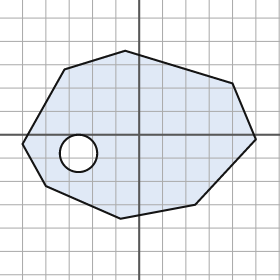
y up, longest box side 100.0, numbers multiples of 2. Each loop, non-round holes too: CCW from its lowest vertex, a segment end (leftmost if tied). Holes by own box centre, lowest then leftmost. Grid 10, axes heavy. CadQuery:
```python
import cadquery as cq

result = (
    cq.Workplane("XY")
    .moveTo(-8.0, -36.0)
    .lineTo(24.0, -30.0)
    .lineTo(50.0, -2.0)
    .lineTo(40.0, 22.0)
    .lineTo(-6.0, 36.0)
    .lineTo(-32.0, 28.0)
    .lineTo(-50.0, -4.0)
    .lineTo(-40.0, -22.0)
    .close()
    .moveTo(-26.0, -8.0)
    .circle(8.0)
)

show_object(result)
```